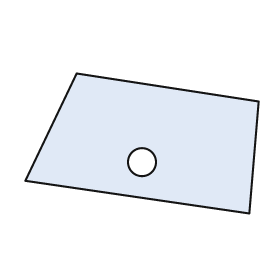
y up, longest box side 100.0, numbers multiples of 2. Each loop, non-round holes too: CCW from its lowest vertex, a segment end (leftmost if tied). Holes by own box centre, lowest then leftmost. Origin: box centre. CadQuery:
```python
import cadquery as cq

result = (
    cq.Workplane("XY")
    .moveTo(46.0, -30.0)
    .lineTo(50.0, 18.0)
    .lineTo(-28.0, 30.0)
    .lineTo(-50.0, -16.0)
    .close()
    .moveTo(0.0, -8.0)
    .circle(6.0)
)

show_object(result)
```